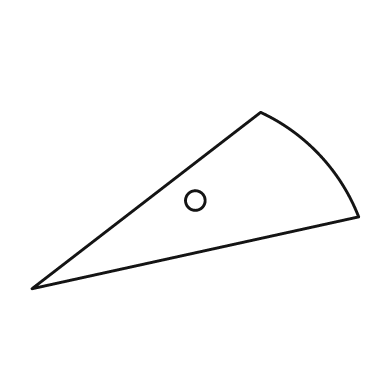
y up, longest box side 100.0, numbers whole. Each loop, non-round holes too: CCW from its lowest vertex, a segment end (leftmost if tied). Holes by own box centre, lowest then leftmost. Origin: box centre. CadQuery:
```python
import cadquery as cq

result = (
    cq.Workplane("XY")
    .moveTo(-50.0, -27.0)
    .lineTo(50.0, -5.0)
    .threePointArc((38.0, 14.0), (20.0, 27.0))
    .close()
    .moveTo(0.0, 0.0)
    .circle(3.0)
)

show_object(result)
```